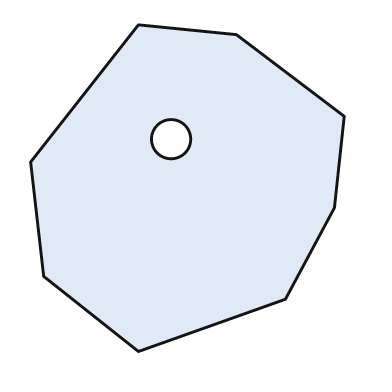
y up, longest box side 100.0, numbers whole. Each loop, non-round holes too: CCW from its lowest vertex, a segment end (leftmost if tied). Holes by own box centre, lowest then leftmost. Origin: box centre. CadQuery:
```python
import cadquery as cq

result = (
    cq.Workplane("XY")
    .moveTo(-15.0, -50.0)
    .lineTo(30.0, -34.0)
    .lineTo(45.0, -6.0)
    .lineTo(48.0, 22.0)
    .lineTo(15.0, 47.0)
    .lineTo(-15.0, 50.0)
    .lineTo(-48.0, 8.0)
    .lineTo(-44.0, -27.0)
    .close()
    .moveTo(-5.0, 15.0)
    .circle(6.0)
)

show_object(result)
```